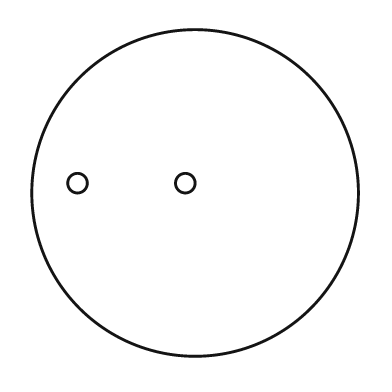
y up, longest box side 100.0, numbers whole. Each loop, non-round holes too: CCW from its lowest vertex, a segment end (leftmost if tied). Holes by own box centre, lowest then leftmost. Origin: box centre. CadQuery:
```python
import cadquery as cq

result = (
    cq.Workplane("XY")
    .moveTo(0.0, 0.0)
    .circle(50.0)
    .moveTo(-36.0, 3.0)
    .circle(3.0)
    .moveTo(-3.0, 3.0)
    .circle(3.0)
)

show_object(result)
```